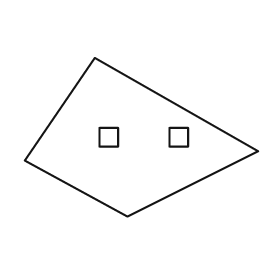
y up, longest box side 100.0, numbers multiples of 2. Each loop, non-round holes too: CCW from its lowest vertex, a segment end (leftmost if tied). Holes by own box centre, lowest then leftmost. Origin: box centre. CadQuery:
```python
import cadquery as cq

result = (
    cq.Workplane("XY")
    .moveTo(-6.0, -34.0)
    .lineTo(50.0, -6.0)
    .lineTo(-20.0, 34.0)
    .lineTo(-50.0, -10.0)
    .close()
    .moveTo(-18.0, -4.0)
    .lineTo(-10.0, -4.0)
    .lineTo(-10.0, 4.0)
    .lineTo(-18.0, 4.0)
    .close()
    .moveTo(12.0, -4.0)
    .lineTo(20.0, -4.0)
    .lineTo(20.0, 4.0)
    .lineTo(12.0, 4.0)
    .close()
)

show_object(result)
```